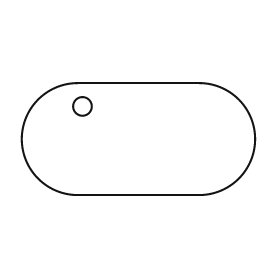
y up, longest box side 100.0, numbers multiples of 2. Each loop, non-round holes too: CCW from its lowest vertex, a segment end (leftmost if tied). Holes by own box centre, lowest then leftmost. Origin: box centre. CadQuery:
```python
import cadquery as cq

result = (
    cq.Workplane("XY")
    .moveTo(-26.0, -24.0)
    .lineTo(26.0, -24.0)
    .threePointArc((50.0, 0.0), (26.0, 24.0))
    .lineTo(-26.0, 24.0)
    .threePointArc((-50.0, 0.0), (-26.0, -24.0))
    .close()
    .moveTo(-24.0, 14.0)
    .circle(4.0)
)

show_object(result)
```